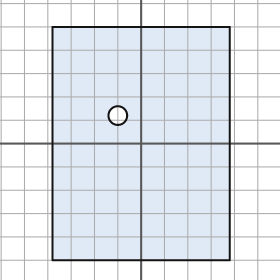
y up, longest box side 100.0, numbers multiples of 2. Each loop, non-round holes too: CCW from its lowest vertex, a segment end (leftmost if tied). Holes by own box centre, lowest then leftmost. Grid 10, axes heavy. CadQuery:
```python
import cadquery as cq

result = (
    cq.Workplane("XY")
    .moveTo(-38.0, -50.0)
    .lineTo(38.0, -50.0)
    .lineTo(38.0, 50.0)
    .lineTo(-38.0, 50.0)
    .close()
    .moveTo(-10.0, 12.0)
    .circle(4.0)
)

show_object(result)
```